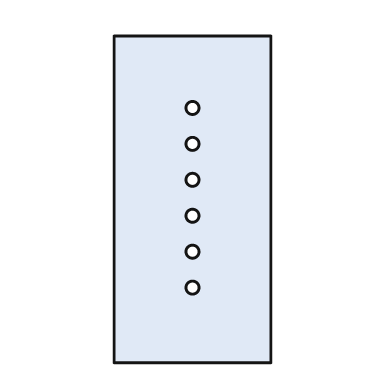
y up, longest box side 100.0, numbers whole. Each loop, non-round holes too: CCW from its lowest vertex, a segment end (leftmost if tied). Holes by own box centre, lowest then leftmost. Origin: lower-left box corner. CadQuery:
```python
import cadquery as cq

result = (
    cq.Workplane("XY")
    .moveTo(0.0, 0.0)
    .lineTo(48.0, 0.0)
    .lineTo(48.0, 100.0)
    .lineTo(0.0, 100.0)
    .close()
    .moveTo(24.0, 23.0)
    .circle(2.0)
    .moveTo(24.0, 34.0)
    .circle(2.0)
    .moveTo(24.0, 45.0)
    .circle(2.0)
    .moveTo(24.0, 56.0)
    .circle(2.0)
    .moveTo(24.0, 67.0)
    .circle(2.0)
    .moveTo(24.0, 78.0)
    .circle(2.0)
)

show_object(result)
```